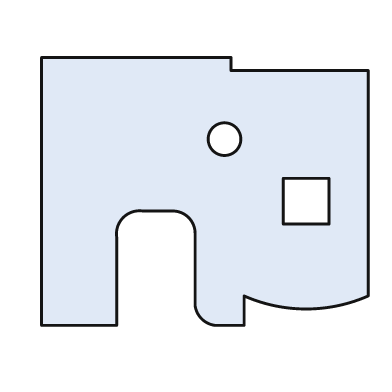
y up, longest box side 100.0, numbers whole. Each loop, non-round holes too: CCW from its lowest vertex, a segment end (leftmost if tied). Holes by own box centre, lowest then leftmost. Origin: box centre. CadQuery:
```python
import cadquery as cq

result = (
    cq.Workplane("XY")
    .moveTo(-50.0, -41.0)
    .lineTo(-27.0, -41.0)
    .lineTo(-27.0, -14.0)
    .threePointArc((-25.0, -8.0), (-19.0, -6.0))
    .lineTo(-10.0, -6.0)
    .threePointArc((-5.0, -8.0), (-3.0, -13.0))
    .lineTo(-3.0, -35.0)
    .threePointArc((-1.0, -39.0), (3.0, -41.0))
    .lineTo(12.0, -41.0)
    .lineTo(12.0, -32.0)
    .threePointArc((31.0, -36.0), (50.0, -32.0))
    .lineTo(50.0, 37.0)
    .lineTo(8.0, 37.0)
    .lineTo(8.0, 41.0)
    .lineTo(-50.0, 41.0)
    .close()
    .moveTo(24.0, -10.0)
    .lineTo(38.0, -10.0)
    .lineTo(38.0, 4.0)
    .lineTo(24.0, 4.0)
    .close()
    .moveTo(6.0, 16.0)
    .circle(5.0)
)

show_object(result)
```